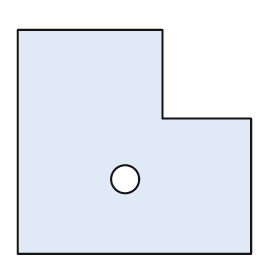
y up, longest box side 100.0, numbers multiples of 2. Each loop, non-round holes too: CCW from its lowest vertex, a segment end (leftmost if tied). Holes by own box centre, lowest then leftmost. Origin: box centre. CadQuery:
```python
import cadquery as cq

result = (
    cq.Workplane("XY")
    .moveTo(-50.0, -48.0)
    .lineTo(50.0, -48.0)
    .lineTo(50.0, 10.0)
    .lineTo(12.0, 10.0)
    .lineTo(12.0, 48.0)
    .lineTo(-50.0, 48.0)
    .close()
    .moveTo(-4.0, -16.0)
    .circle(6.0)
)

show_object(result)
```